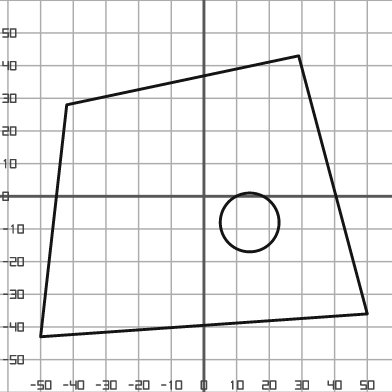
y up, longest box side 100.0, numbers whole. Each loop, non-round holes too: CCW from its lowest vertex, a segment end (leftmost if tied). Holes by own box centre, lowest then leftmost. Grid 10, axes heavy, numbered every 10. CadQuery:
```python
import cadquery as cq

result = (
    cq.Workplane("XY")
    .moveTo(-50.0, -43.0)
    .lineTo(50.0, -36.0)
    .lineTo(29.0, 43.0)
    .lineTo(-42.0, 28.0)
    .close()
    .moveTo(14.0, -8.0)
    .circle(9.0)
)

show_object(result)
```